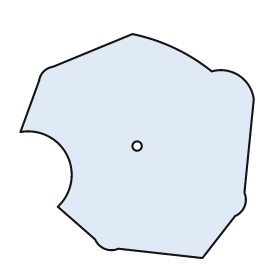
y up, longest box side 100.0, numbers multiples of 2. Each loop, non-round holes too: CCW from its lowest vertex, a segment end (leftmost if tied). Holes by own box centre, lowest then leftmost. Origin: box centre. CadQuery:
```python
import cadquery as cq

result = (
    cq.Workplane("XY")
    .moveTo(28.0, -48.0)
    .lineTo(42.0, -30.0)
    .threePointArc((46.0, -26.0), (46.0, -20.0))
    .lineTo(50.0, 20.0)
    .threePointArc((44.0, 30.0), (32.0, 32.0))
    .threePointArc((16.0, 42.0), (-2.0, 48.0))
    .lineTo(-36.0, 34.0)
    .threePointArc((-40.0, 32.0), (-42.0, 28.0))
    .lineTo(-50.0, 6.0)
    .threePointArc((-30.0, -4.0), (-34.0, -26.0))
    .lineTo(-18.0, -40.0)
    .threePointArc((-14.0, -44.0), (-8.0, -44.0))
    .close()
    .moveTo(0.0, 0.0)
    .circle(2.0)
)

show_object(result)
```